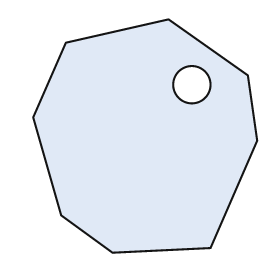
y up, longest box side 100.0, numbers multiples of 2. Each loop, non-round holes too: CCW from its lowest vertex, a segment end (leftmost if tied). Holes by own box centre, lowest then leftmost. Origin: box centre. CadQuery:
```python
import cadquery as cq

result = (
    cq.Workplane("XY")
    .moveTo(-14.0, -50.0)
    .lineTo(28.0, -48.0)
    .lineTo(48.0, -2.0)
    .lineTo(44.0, 26.0)
    .lineTo(10.0, 50.0)
    .lineTo(-34.0, 40.0)
    .lineTo(-48.0, 8.0)
    .lineTo(-36.0, -34.0)
    .close()
    .moveTo(20.0, 22.0)
    .circle(8.0)
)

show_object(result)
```